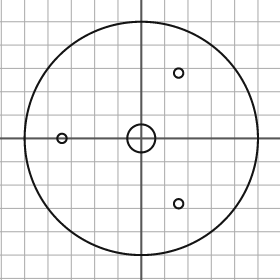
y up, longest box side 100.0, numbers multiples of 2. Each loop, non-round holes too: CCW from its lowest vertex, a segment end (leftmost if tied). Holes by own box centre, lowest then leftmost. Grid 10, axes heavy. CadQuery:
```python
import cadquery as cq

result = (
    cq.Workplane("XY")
    .moveTo(0.0, 0.0)
    .circle(50.0)
    .moveTo(16.0, -28.0)
    .circle(2.0)
    .moveTo(-34.0, 0.0)
    .circle(2.0)
    .moveTo(0.0, 0.0)
    .circle(6.0)
    .moveTo(16.0, 28.0)
    .circle(2.0)
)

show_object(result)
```